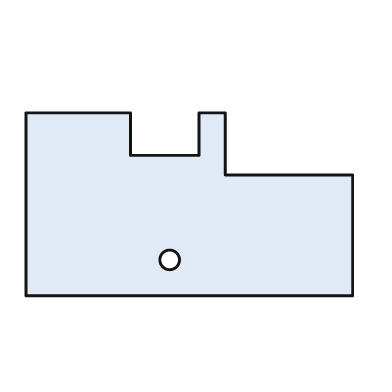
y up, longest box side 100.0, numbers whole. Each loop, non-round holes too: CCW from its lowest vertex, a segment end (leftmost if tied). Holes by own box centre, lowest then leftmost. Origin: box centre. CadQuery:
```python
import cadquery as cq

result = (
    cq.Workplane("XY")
    .moveTo(-50.0, -28.0)
    .lineTo(50.0, -28.0)
    .lineTo(50.0, 9.0)
    .lineTo(11.0, 9.0)
    .lineTo(11.0, 28.0)
    .lineTo(3.0, 28.0)
    .lineTo(3.0, 15.0)
    .lineTo(-18.0, 15.0)
    .lineTo(-18.0, 28.0)
    .lineTo(-50.0, 28.0)
    .close()
    .moveTo(-6.0, -17.0)
    .circle(3.0)
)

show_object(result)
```